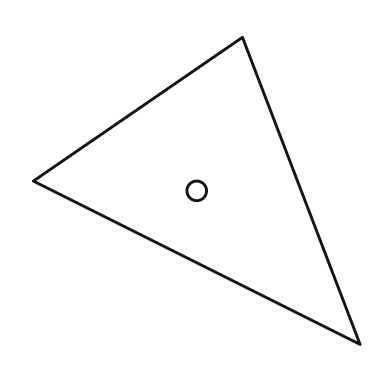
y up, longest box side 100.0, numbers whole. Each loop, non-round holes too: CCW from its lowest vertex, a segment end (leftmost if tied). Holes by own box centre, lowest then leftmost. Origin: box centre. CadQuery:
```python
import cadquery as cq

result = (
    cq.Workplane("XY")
    .moveTo(50.0, -47.0)
    .lineTo(14.0, 47.0)
    .lineTo(-50.0, 3.0)
    .close()
    .moveTo(0.0, 0.0)
    .circle(3.0)
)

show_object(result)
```